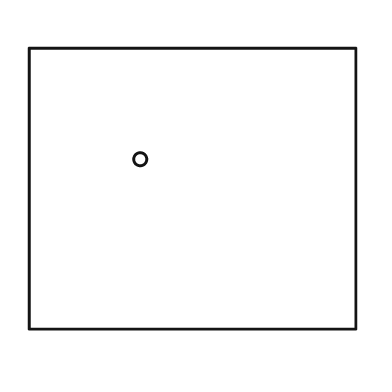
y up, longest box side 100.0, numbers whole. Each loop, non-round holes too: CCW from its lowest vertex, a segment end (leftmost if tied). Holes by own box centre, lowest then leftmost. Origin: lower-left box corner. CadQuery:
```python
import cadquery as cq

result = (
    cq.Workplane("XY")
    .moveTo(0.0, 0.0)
    .lineTo(100.0, 0.0)
    .lineTo(100.0, 86.0)
    .lineTo(0.0, 86.0)
    .close()
    .moveTo(34.0, 52.0)
    .circle(2.0)
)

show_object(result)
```